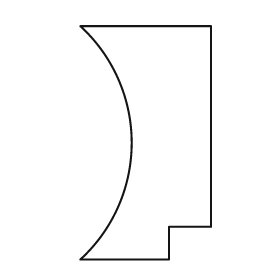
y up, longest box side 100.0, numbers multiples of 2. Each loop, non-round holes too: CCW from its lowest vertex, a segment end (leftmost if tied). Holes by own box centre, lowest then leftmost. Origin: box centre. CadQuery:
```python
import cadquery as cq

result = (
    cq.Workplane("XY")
    .moveTo(-28.0, -50.0)
    .lineTo(10.0, -50.0)
    .lineTo(10.0, -36.0)
    .lineTo(28.0, -36.0)
    .lineTo(28.0, 50.0)
    .lineTo(-28.0, 50.0)
    .threePointArc((-6.0, 0.0), (-28.0, -50.0))
    .close()
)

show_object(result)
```